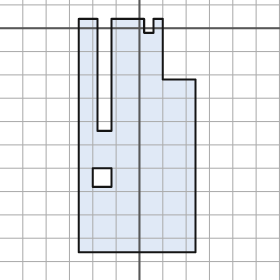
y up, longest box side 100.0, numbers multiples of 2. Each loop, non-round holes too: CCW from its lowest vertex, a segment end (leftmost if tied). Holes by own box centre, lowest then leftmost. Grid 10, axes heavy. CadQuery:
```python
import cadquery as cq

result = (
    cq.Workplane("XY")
    .moveTo(-26.0, -96.0)
    .lineTo(24.0, -96.0)
    .lineTo(24.0, -22.0)
    .lineTo(10.0, -22.0)
    .lineTo(10.0, 4.0)
    .lineTo(6.0, 4.0)
    .lineTo(6.0, -2.0)
    .lineTo(2.0, -2.0)
    .lineTo(2.0, 4.0)
    .lineTo(-12.0, 4.0)
    .lineTo(-12.0, -44.0)
    .lineTo(-18.0, -44.0)
    .lineTo(-18.0, 4.0)
    .lineTo(-26.0, 4.0)
    .close()
    .moveTo(-20.0, -68.0)
    .lineTo(-12.0, -68.0)
    .lineTo(-12.0, -60.0)
    .lineTo(-20.0, -60.0)
    .close()
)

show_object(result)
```